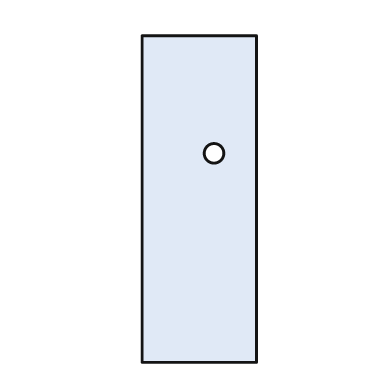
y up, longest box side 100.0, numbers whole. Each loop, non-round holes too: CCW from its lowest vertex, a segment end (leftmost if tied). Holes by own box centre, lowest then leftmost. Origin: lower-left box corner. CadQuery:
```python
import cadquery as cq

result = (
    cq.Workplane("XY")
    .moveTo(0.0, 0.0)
    .lineTo(35.0, 0.0)
    .lineTo(35.0, 100.0)
    .lineTo(0.0, 100.0)
    .close()
    .moveTo(22.0, 64.0)
    .circle(3.0)
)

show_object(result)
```